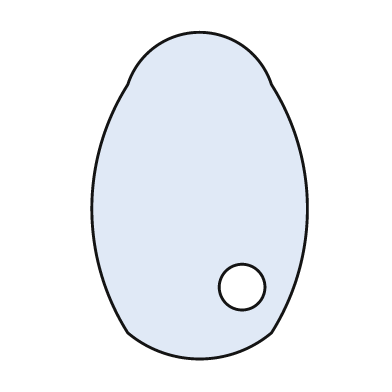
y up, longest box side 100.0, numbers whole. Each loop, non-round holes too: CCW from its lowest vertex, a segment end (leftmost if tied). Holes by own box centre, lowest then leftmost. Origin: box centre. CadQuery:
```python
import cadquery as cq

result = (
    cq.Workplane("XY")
    .moveTo(-22.0, -42.0)
    .threePointArc((0.0, -50.0), (22.0, -42.0))
    .threePointArc((33.0, -4.0), (22.0, 34.0))
    .threePointArc((0.0, 50.0), (-22.0, 34.0))
    .threePointArc((-33.0, -4.0), (-22.0, -42.0))
    .close()
    .moveTo(13.0, -28.0)
    .circle(7.0)
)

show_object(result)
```